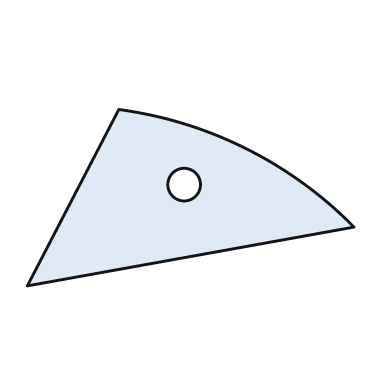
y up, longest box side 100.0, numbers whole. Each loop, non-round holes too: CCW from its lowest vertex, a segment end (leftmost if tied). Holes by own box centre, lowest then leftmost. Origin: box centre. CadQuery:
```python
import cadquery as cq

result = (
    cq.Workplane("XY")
    .moveTo(-50.0, -27.0)
    .lineTo(50.0, -9.0)
    .threePointArc((17.0, 15.0), (-22.0, 27.0))
    .close()
    .moveTo(-2.0, 4.0)
    .circle(5.0)
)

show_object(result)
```